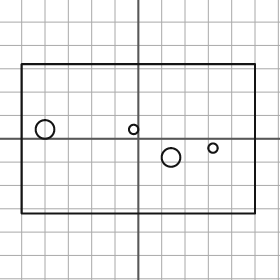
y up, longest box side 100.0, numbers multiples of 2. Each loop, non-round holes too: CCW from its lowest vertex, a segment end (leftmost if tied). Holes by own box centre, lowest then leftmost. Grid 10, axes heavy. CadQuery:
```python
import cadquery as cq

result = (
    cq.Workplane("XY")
    .moveTo(-50.0, -32.0)
    .lineTo(50.0, -32.0)
    .lineTo(50.0, 32.0)
    .lineTo(-50.0, 32.0)
    .close()
    .moveTo(14.0, -8.0)
    .circle(4.0)
    .moveTo(32.0, -4.0)
    .circle(2.0)
    .moveTo(-40.0, 4.0)
    .circle(4.0)
    .moveTo(-2.0, 4.0)
    .circle(2.0)
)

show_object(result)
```